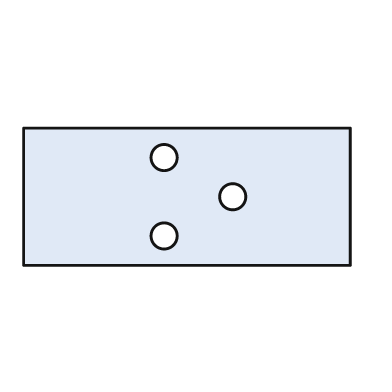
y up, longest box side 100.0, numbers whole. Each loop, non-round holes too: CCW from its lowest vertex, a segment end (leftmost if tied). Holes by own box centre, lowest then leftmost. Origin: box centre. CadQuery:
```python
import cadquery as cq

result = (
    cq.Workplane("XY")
    .moveTo(-50.0, -21.0)
    .lineTo(50.0, -21.0)
    .lineTo(50.0, 21.0)
    .lineTo(-50.0, 21.0)
    .close()
    .moveTo(-7.0, -12.0)
    .circle(4.0)
    .moveTo(14.0, 0.0)
    .circle(4.0)
    .moveTo(-7.0, 12.0)
    .circle(4.0)
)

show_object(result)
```